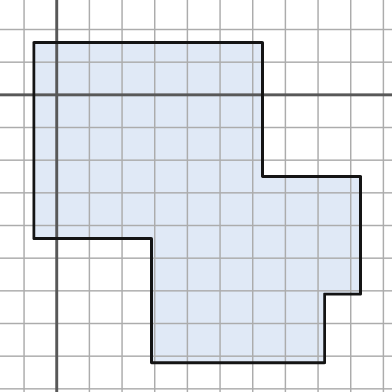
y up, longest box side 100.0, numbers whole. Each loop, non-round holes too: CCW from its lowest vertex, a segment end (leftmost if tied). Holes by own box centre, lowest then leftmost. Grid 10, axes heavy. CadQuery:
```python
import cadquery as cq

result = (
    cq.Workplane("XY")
    .moveTo(29.0, -82.0)
    .lineTo(82.0, -82.0)
    .lineTo(82.0, -61.0)
    .lineTo(93.0, -61.0)
    .lineTo(93.0, -25.0)
    .lineTo(63.0, -25.0)
    .lineTo(63.0, 16.0)
    .lineTo(-7.0, 16.0)
    .lineTo(-7.0, -44.0)
    .lineTo(29.0, -44.0)
    .close()
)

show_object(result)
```